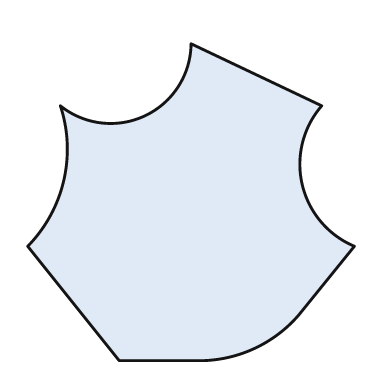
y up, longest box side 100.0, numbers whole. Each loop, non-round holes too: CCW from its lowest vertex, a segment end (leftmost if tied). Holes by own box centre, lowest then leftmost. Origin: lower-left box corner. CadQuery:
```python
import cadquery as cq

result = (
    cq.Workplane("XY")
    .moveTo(28.0, 0.0)
    .lineTo(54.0, 0.0)
    .threePointArc((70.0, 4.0), (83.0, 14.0))
    .lineTo(100.0, 35.0)
    .threePointArc((84.0, 54.0), (90.0, 78.0))
    .lineTo(50.0, 97.0)
    .threePointArc((36.0, 75.0), (10.0, 78.0))
    .threePointArc((11.0, 55.0), (0.0, 35.0))
    .close()
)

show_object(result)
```